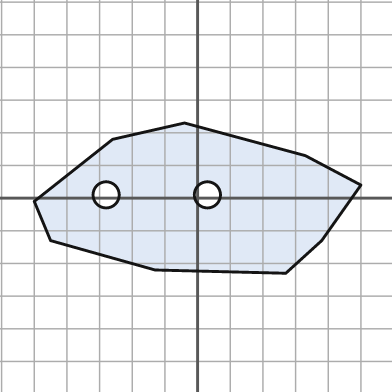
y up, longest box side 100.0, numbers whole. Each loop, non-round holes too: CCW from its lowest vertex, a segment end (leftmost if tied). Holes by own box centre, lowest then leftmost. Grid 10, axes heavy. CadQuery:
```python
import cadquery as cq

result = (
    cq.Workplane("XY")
    .moveTo(27.0, -23.0)
    .lineTo(38.0, -13.0)
    .lineTo(50.0, 4.0)
    .lineTo(33.0, 13.0)
    .lineTo(-4.0, 23.0)
    .lineTo(-26.0, 18.0)
    .lineTo(-50.0, -1.0)
    .lineTo(-45.0, -13.0)
    .lineTo(-13.0, -22.0)
    .close()
    .moveTo(-28.0, 1.0)
    .circle(4.0)
    .moveTo(3.0, 1.0)
    .circle(4.0)
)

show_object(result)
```